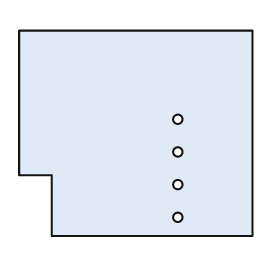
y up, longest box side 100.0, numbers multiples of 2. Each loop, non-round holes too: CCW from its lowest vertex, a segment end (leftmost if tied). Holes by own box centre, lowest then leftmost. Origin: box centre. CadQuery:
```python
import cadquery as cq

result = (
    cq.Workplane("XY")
    .moveTo(-36.0, -44.0)
    .lineTo(50.0, -44.0)
    .lineTo(50.0, 44.0)
    .lineTo(-50.0, 44.0)
    .lineTo(-50.0, -18.0)
    .lineTo(-36.0, -18.0)
    .close()
    .moveTo(18.0, -36.0)
    .circle(2.0)
    .moveTo(18.0, -22.0)
    .circle(2.0)
    .moveTo(18.0, -8.0)
    .circle(2.0)
    .moveTo(18.0, 6.0)
    .circle(2.0)
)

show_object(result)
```